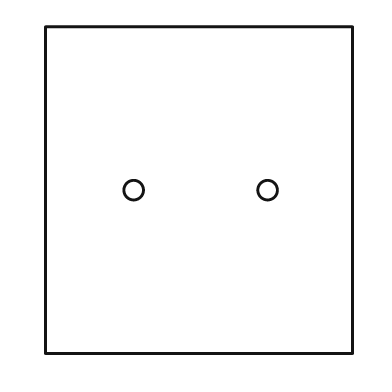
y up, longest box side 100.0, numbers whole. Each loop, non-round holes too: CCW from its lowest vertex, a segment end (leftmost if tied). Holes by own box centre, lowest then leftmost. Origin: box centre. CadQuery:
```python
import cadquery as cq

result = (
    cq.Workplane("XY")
    .moveTo(-47.0, -50.0)
    .lineTo(47.0, -50.0)
    .lineTo(47.0, 50.0)
    .lineTo(-47.0, 50.0)
    .close()
    .moveTo(-20.0, 0.0)
    .circle(3.0)
    .moveTo(21.0, 0.0)
    .circle(3.0)
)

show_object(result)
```